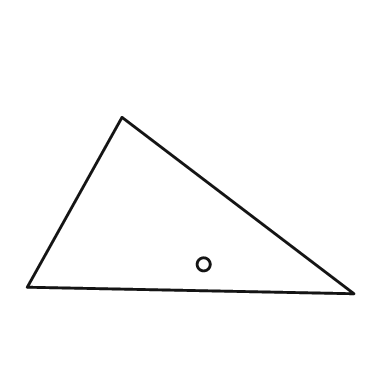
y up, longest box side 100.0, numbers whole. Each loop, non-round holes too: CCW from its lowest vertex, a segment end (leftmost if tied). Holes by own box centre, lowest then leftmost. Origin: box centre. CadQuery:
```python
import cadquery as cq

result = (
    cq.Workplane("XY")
    .moveTo(50.0, -27.0)
    .lineTo(-21.0, 27.0)
    .lineTo(-50.0, -25.0)
    .close()
    .moveTo(4.0, -18.0)
    .circle(2.0)
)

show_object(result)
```